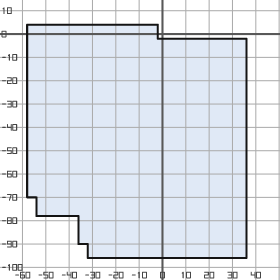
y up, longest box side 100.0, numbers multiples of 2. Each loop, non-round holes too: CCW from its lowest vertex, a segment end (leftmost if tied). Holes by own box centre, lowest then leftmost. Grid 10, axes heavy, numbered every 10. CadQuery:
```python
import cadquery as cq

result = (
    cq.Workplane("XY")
    .moveTo(-32.0, -96.0)
    .lineTo(36.0, -96.0)
    .lineTo(36.0, -2.0)
    .lineTo(-2.0, -2.0)
    .lineTo(-2.0, 4.0)
    .lineTo(-58.0, 4.0)
    .lineTo(-58.0, -70.0)
    .lineTo(-54.0, -70.0)
    .lineTo(-54.0, -78.0)
    .lineTo(-36.0, -78.0)
    .lineTo(-36.0, -90.0)
    .lineTo(-32.0, -90.0)
    .close()
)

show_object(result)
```